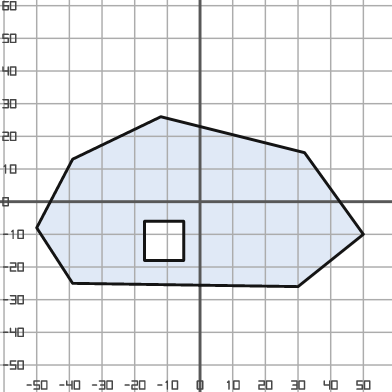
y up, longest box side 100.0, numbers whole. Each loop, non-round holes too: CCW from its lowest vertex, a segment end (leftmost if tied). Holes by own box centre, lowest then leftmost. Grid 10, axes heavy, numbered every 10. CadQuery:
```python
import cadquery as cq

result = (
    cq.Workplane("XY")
    .moveTo(30.0, -26.0)
    .lineTo(50.0, -10.0)
    .lineTo(32.0, 15.0)
    .lineTo(-12.0, 26.0)
    .lineTo(-39.0, 13.0)
    .lineTo(-50.0, -8.0)
    .lineTo(-39.0, -25.0)
    .close()
    .moveTo(-17.0, -18.0)
    .lineTo(-5.0, -18.0)
    .lineTo(-5.0, -6.0)
    .lineTo(-17.0, -6.0)
    .close()
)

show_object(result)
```